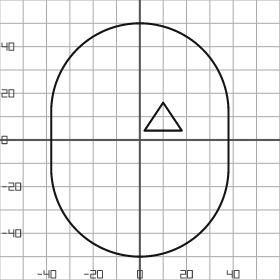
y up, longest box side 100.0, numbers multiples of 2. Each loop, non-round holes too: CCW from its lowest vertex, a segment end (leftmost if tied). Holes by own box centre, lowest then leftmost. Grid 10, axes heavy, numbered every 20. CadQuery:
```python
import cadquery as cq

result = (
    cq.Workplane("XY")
    .moveTo(-38.0, -12.0)
    .threePointArc((0.0, -50.0), (38.0, -12.0))
    .lineTo(38.0, 12.0)
    .threePointArc((0.0, 50.0), (-38.0, 12.0))
    .close()
    .moveTo(2.0, 4.0)
    .lineTo(18.0, 4.0)
    .lineTo(10.0, 16.0)
    .close()
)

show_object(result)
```